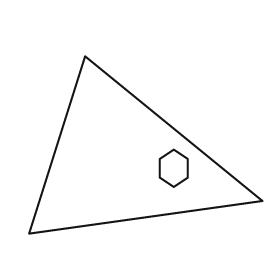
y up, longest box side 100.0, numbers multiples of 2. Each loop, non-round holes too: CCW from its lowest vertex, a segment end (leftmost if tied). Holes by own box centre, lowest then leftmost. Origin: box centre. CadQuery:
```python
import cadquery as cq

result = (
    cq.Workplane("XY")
    .moveTo(-50.0, -38.0)
    .lineTo(50.0, -24.0)
    .lineTo(-26.0, 38.0)
    .close()
    .moveTo(12.0, -18.0)
    .lineTo(18.0, -14.0)
    .lineTo(18.0, -6.0)
    .lineTo(12.0, -2.0)
    .lineTo(6.0, -6.0)
    .lineTo(6.0, -14.0)
    .close()
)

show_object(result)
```